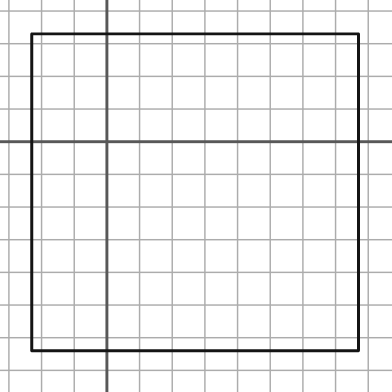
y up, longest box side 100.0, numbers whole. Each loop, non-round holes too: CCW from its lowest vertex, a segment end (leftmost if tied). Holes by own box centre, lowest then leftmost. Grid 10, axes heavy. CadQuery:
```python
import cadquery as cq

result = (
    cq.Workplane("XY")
    .moveTo(-23.0, -64.0)
    .lineTo(77.0, -64.0)
    .lineTo(77.0, 33.0)
    .lineTo(-23.0, 33.0)
    .close()
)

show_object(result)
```